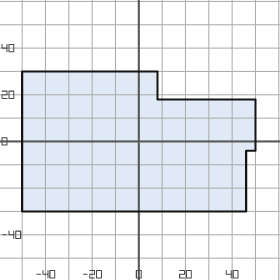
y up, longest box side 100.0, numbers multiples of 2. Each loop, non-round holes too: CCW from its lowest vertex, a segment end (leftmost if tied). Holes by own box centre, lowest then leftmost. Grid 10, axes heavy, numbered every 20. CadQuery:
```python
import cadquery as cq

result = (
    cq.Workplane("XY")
    .moveTo(-50.0, -30.0)
    .lineTo(46.0, -30.0)
    .lineTo(46.0, -4.0)
    .lineTo(50.0, -4.0)
    .lineTo(50.0, 18.0)
    .lineTo(8.0, 18.0)
    .lineTo(8.0, 30.0)
    .lineTo(-50.0, 30.0)
    .close()
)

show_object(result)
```